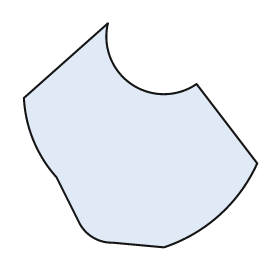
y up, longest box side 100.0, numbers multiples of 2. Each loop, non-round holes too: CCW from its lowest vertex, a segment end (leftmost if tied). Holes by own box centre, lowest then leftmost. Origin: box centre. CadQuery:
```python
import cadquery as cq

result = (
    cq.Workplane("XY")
    .moveTo(10.0, -48.0)
    .threePointArc((34.0, -34.0), (50.0, -12.0))
    .lineTo(24.0, 22.0)
    .threePointArc((-4.0, 22.0), (-14.0, 48.0))
    .lineTo(-50.0, 16.0)
    .threePointArc((-46.0, -2.0), (-36.0, -18.0))
    .lineTo(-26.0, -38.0)
    .threePointArc((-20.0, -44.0), (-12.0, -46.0))
    .close()
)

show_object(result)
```